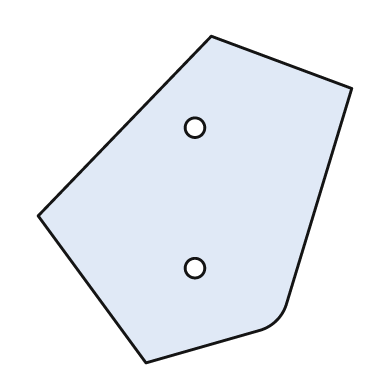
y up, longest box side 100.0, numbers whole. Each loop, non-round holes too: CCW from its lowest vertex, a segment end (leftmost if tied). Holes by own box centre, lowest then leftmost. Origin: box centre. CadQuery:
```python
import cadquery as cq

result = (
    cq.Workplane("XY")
    .moveTo(-15.0, -50.0)
    .lineTo(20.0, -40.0)
    .threePointArc((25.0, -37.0), (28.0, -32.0))
    .lineTo(48.0, 34.0)
    .lineTo(5.0, 50.0)
    .lineTo(-48.0, -5.0)
    .close()
    .moveTo(0.0, -21.0)
    .circle(3.0)
    .moveTo(0.0, 22.0)
    .circle(3.0)
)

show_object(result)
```